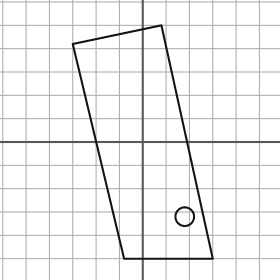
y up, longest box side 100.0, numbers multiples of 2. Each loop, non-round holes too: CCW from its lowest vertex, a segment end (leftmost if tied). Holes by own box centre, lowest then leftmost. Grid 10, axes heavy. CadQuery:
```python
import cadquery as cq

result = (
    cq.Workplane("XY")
    .moveTo(-8.0, -50.0)
    .lineTo(30.0, -50.0)
    .lineTo(8.0, 50.0)
    .lineTo(-30.0, 42.0)
    .close()
    .moveTo(18.0, -32.0)
    .circle(4.0)
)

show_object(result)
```